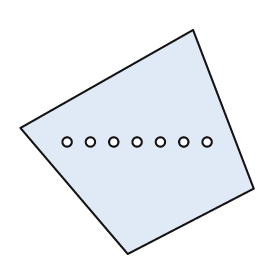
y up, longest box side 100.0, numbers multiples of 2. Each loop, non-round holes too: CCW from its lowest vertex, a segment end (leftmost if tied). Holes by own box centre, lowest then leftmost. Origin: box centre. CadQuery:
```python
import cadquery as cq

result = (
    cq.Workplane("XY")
    .moveTo(-4.0, -48.0)
    .lineTo(50.0, -20.0)
    .lineTo(24.0, 48.0)
    .lineTo(-50.0, 6.0)
    .close()
    .moveTo(-30.0, 0.0)
    .circle(2.0)
    .moveTo(-20.0, 0.0)
    .circle(2.0)
    .moveTo(-10.0, 0.0)
    .circle(2.0)
    .moveTo(0.0, 0.0)
    .circle(2.0)
    .moveTo(10.0, 0.0)
    .circle(2.0)
    .moveTo(20.0, 0.0)
    .circle(2.0)
    .moveTo(30.0, 0.0)
    .circle(2.0)
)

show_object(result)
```